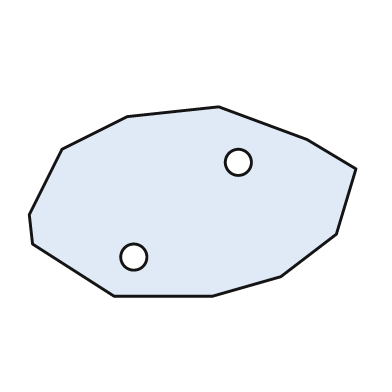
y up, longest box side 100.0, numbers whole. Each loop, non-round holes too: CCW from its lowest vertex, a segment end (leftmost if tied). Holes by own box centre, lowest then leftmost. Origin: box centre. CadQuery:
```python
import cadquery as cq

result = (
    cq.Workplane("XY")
    .moveTo(-24.0, -29.0)
    .lineTo(6.0, -29.0)
    .lineTo(27.0, -23.0)
    .lineTo(44.0, -10.0)
    .lineTo(50.0, 10.0)
    .lineTo(35.0, 19.0)
    .lineTo(8.0, 29.0)
    .lineTo(-20.0, 26.0)
    .lineTo(-40.0, 16.0)
    .lineTo(-50.0, -4.0)
    .lineTo(-49.0, -13.0)
    .close()
    .moveTo(-18.0, -17.0)
    .circle(4.0)
    .moveTo(14.0, 12.0)
    .circle(4.0)
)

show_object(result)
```